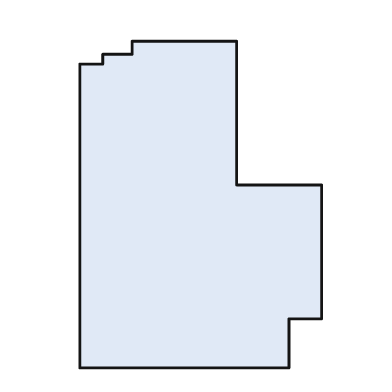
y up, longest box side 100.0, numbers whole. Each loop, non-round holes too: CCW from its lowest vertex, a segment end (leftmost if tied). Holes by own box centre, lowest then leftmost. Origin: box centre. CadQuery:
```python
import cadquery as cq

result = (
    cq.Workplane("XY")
    .moveTo(-37.0, -50.0)
    .lineTo(27.0, -50.0)
    .lineTo(27.0, -35.0)
    .lineTo(37.0, -35.0)
    .lineTo(37.0, 6.0)
    .lineTo(11.0, 6.0)
    .lineTo(11.0, 50.0)
    .lineTo(-21.0, 50.0)
    .lineTo(-21.0, 46.0)
    .lineTo(-30.0, 46.0)
    .lineTo(-30.0, 43.0)
    .lineTo(-37.0, 43.0)
    .close()
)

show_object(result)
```